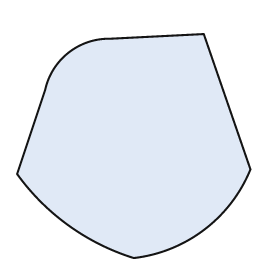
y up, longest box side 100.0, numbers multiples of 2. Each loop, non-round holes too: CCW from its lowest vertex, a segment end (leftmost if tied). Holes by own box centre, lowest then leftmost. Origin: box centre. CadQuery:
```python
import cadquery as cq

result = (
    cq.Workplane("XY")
    .moveTo(0.0, -48.0)
    .threePointArc((30.0, -36.0), (50.0, -10.0))
    .lineTo(30.0, 48.0)
    .lineTo(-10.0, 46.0)
    .threePointArc((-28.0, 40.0), (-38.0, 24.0))
    .lineTo(-50.0, -12.0)
    .threePointArc((-28.0, -34.0), (0.0, -48.0))
    .close()
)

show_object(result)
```